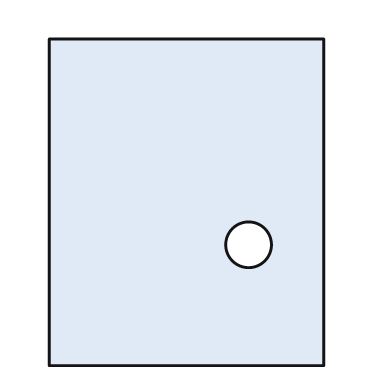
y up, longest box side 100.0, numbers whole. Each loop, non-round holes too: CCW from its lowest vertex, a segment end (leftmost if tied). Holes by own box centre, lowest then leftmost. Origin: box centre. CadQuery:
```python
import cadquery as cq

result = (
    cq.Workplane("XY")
    .moveTo(-42.0, -50.0)
    .lineTo(42.0, -50.0)
    .lineTo(42.0, 50.0)
    .lineTo(-42.0, 50.0)
    .close()
    .moveTo(19.0, -13.0)
    .circle(7.0)
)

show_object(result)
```